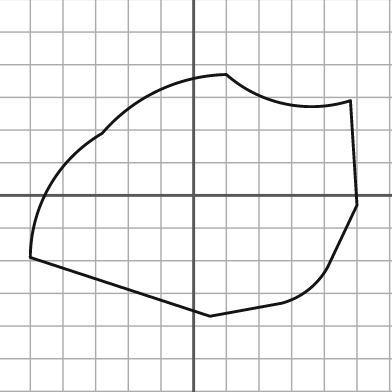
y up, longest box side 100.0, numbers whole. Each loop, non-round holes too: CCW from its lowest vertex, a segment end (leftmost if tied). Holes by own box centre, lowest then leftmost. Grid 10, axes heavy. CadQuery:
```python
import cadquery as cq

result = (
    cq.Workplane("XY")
    .moveTo(5.0, -37.0)
    .lineTo(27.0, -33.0)
    .threePointArc((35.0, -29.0), (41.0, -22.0))
    .lineTo(50.0, -3.0)
    .lineTo(48.0, 29.0)
    .threePointArc((28.0, 28.0), (10.0, 37.0))
    .threePointArc((-11.0, 32.0), (-28.0, 19.0))
    .threePointArc((-44.0, 3.0), (-50.0, -19.0))
    .close()
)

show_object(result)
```